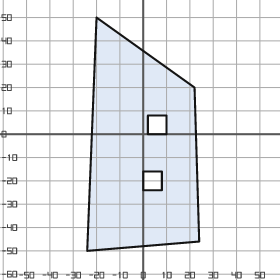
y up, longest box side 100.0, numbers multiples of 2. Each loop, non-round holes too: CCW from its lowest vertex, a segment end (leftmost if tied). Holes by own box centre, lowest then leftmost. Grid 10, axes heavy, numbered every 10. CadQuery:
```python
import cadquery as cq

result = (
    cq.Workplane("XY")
    .moveTo(-24.0, -50.0)
    .lineTo(24.0, -46.0)
    .lineTo(22.0, 20.0)
    .lineTo(-20.0, 50.0)
    .close()
    .moveTo(0.0, -24.0)
    .lineTo(8.0, -24.0)
    .lineTo(8.0, -16.0)
    .lineTo(0.0, -16.0)
    .close()
    .moveTo(2.0, 0.0)
    .lineTo(10.0, 0.0)
    .lineTo(10.0, 8.0)
    .lineTo(2.0, 8.0)
    .close()
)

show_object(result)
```